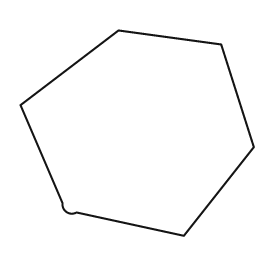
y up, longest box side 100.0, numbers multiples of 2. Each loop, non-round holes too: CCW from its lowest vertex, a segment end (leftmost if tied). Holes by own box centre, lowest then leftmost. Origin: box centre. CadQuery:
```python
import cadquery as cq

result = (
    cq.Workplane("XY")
    .moveTo(20.0, -44.0)
    .lineTo(50.0, -6.0)
    .lineTo(36.0, 38.0)
    .lineTo(-8.0, 44.0)
    .lineTo(-50.0, 12.0)
    .lineTo(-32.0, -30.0)
    .threePointArc((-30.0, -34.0), (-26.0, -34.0))
    .close()
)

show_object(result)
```